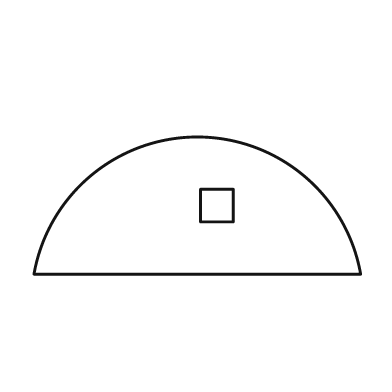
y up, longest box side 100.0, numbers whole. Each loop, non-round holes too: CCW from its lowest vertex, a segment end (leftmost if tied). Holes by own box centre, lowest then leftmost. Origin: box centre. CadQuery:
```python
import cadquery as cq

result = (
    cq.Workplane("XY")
    .moveTo(-50.0, -21.0)
    .lineTo(50.0, -21.0)
    .threePointArc((0.0, 21.0), (-50.0, -21.0))
    .close()
    .moveTo(1.0, -5.0)
    .lineTo(11.0, -5.0)
    .lineTo(11.0, 5.0)
    .lineTo(1.0, 5.0)
    .close()
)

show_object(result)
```